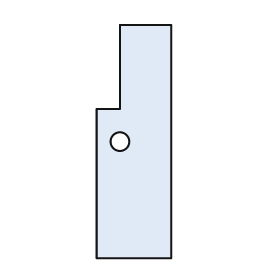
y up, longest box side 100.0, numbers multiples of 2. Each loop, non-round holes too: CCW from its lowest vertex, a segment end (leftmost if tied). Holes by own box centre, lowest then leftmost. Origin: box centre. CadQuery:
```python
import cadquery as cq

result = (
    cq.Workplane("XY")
    .moveTo(-16.0, -50.0)
    .lineTo(16.0, -50.0)
    .lineTo(16.0, 50.0)
    .lineTo(-6.0, 50.0)
    .lineTo(-6.0, 14.0)
    .lineTo(-16.0, 14.0)
    .close()
    .moveTo(-6.0, 0.0)
    .circle(4.0)
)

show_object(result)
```